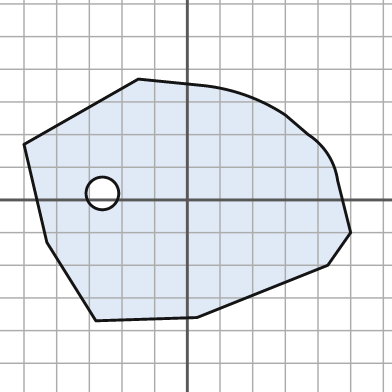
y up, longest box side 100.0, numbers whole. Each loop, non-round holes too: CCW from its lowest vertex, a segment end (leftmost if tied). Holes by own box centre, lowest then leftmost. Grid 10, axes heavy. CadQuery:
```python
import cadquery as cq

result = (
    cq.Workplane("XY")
    .moveTo(-28.0, -37.0)
    .lineTo(3.0, -36.0)
    .lineTo(43.0, -20.0)
    .lineTo(50.0, -10.0)
    .lineTo(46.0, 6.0)
    .threePointArc((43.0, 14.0), (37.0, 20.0))
    .lineTo(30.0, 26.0)
    .threePointArc((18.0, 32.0), (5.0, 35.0))
    .lineTo(-15.0, 37.0)
    .lineTo(-50.0, 17.0)
    .lineTo(-43.0, -13.0)
    .close()
    .moveTo(-26.0, 2.0)
    .circle(5.0)
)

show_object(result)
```